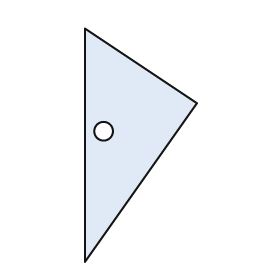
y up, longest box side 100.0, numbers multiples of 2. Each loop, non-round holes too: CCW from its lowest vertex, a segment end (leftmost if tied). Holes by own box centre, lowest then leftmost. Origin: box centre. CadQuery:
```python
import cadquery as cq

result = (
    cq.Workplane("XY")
    .moveTo(-24.0, -50.0)
    .lineTo(24.0, 18.0)
    .lineTo(-24.0, 50.0)
    .close()
    .moveTo(-16.0, 6.0)
    .circle(4.0)
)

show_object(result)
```